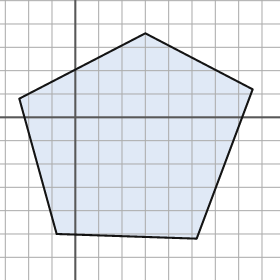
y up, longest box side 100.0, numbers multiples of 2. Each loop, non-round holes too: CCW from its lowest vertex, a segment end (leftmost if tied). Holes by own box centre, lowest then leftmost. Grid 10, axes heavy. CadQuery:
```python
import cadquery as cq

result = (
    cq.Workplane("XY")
    .moveTo(52.0, -52.0)
    .lineTo(76.0, 12.0)
    .lineTo(30.0, 36.0)
    .lineTo(-24.0, 8.0)
    .lineTo(-8.0, -50.0)
    .close()
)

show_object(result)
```